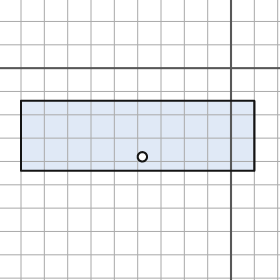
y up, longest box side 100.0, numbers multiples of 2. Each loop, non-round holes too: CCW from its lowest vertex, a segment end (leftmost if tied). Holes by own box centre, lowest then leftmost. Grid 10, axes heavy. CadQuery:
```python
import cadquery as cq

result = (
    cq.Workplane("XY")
    .moveTo(-90.0, -44.0)
    .lineTo(10.0, -44.0)
    .lineTo(10.0, -14.0)
    .lineTo(-90.0, -14.0)
    .close()
    .moveTo(-38.0, -38.0)
    .circle(2.0)
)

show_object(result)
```